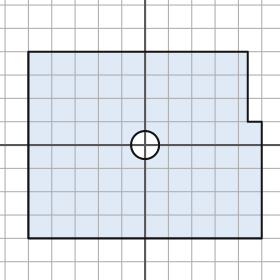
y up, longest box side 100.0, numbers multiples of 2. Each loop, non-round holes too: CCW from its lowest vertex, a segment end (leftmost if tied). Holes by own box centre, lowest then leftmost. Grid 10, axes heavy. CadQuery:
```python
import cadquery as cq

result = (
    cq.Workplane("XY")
    .moveTo(-50.0, -40.0)
    .lineTo(50.0, -40.0)
    .lineTo(50.0, 10.0)
    .lineTo(44.0, 10.0)
    .lineTo(44.0, 40.0)
    .lineTo(-50.0, 40.0)
    .close()
    .moveTo(0.0, 0.0)
    .circle(6.0)
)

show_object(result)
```